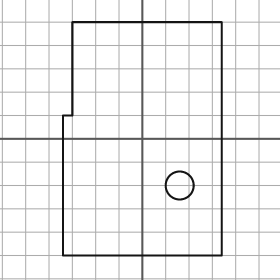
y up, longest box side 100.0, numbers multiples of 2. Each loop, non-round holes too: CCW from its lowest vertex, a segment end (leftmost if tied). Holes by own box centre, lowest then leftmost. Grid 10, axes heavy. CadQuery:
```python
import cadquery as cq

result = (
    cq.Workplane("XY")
    .moveTo(-34.0, -50.0)
    .lineTo(34.0, -50.0)
    .lineTo(34.0, 50.0)
    .lineTo(-30.0, 50.0)
    .lineTo(-30.0, 10.0)
    .lineTo(-34.0, 10.0)
    .close()
    .moveTo(16.0, -20.0)
    .circle(6.0)
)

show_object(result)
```